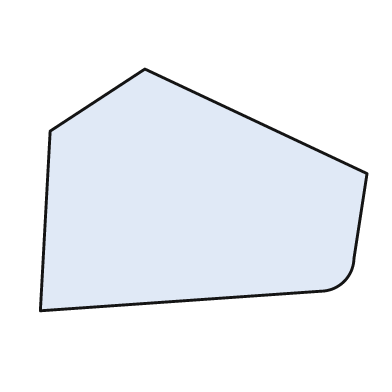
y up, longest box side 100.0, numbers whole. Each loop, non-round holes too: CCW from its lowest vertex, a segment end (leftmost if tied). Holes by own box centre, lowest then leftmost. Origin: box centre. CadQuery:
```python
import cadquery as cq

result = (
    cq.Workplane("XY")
    .moveTo(-50.0, -37.0)
    .lineTo(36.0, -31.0)
    .threePointArc((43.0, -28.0), (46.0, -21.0))
    .lineTo(50.0, 5.0)
    .lineTo(-18.0, 37.0)
    .lineTo(-47.0, 18.0)
    .close()
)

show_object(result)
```